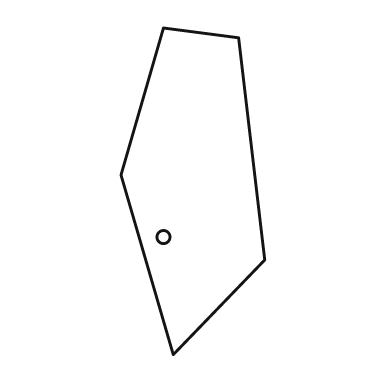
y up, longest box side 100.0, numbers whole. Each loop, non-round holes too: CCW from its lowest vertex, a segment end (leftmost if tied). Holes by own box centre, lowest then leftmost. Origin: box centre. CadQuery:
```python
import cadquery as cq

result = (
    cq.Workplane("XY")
    .moveTo(-6.0, -50.0)
    .lineTo(22.0, -21.0)
    .lineTo(14.0, 47.0)
    .lineTo(-9.0, 50.0)
    .lineTo(-22.0, 5.0)
    .close()
    .moveTo(-9.0, -14.0)
    .circle(2.0)
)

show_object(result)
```